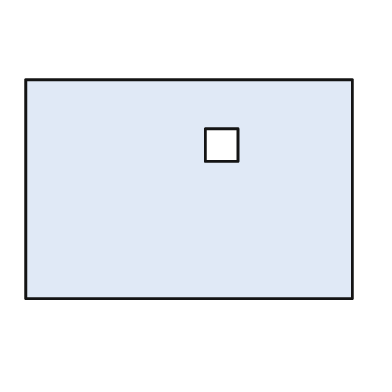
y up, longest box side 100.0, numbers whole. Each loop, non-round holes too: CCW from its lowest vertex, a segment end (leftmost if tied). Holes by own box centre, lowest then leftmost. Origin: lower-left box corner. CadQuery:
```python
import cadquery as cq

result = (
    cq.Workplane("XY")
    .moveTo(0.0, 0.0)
    .lineTo(100.0, 0.0)
    .lineTo(100.0, 67.0)
    .lineTo(0.0, 67.0)
    .close()
    .moveTo(55.0, 42.0)
    .lineTo(65.0, 42.0)
    .lineTo(65.0, 52.0)
    .lineTo(55.0, 52.0)
    .close()
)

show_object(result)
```